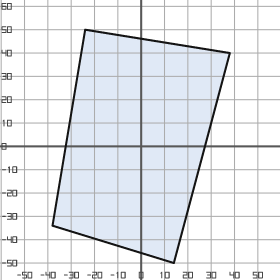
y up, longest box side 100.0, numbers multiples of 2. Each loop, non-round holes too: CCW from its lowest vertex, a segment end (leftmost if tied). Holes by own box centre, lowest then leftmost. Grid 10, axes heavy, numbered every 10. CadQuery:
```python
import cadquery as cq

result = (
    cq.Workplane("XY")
    .moveTo(14.0, -50.0)
    .lineTo(38.0, 40.0)
    .lineTo(-24.0, 50.0)
    .lineTo(-38.0, -34.0)
    .close()
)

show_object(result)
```